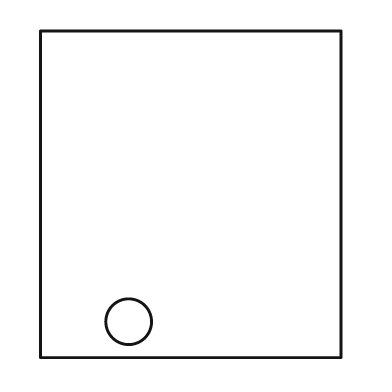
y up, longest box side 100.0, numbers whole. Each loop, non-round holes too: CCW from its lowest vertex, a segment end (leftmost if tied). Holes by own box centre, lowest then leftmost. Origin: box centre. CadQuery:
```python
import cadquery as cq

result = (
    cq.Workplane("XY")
    .moveTo(-46.0, -50.0)
    .lineTo(46.0, -50.0)
    .lineTo(46.0, 50.0)
    .lineTo(-46.0, 50.0)
    .close()
    .moveTo(-19.0, -39.0)
    .circle(7.0)
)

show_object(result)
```